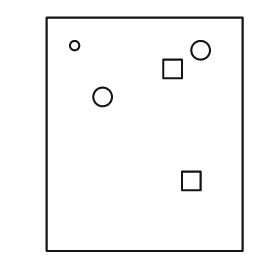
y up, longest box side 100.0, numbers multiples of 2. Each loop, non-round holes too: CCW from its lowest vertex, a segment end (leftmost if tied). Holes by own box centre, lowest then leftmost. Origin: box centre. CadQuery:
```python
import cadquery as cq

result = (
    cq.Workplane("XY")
    .moveTo(-42.0, -50.0)
    .lineTo(42.0, -50.0)
    .lineTo(42.0, 50.0)
    .lineTo(-42.0, 50.0)
    .close()
    .moveTo(16.0, -24.0)
    .lineTo(24.0, -24.0)
    .lineTo(24.0, -16.0)
    .lineTo(16.0, -16.0)
    .close()
    .moveTo(-18.0, 16.0)
    .circle(4.0)
    .moveTo(8.0, 24.0)
    .lineTo(16.0, 24.0)
    .lineTo(16.0, 32.0)
    .lineTo(8.0, 32.0)
    .close()
    .moveTo(24.0, 36.0)
    .circle(4.0)
    .moveTo(-30.0, 38.0)
    .circle(2.0)
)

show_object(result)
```